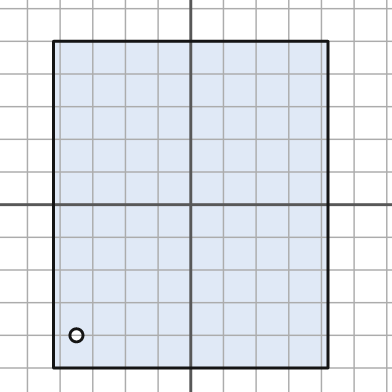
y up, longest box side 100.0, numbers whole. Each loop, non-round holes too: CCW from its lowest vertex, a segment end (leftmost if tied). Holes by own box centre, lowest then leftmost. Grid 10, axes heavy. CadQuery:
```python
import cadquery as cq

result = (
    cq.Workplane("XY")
    .moveTo(-42.0, -50.0)
    .lineTo(42.0, -50.0)
    .lineTo(42.0, 50.0)
    .lineTo(-42.0, 50.0)
    .close()
    .moveTo(-35.0, -40.0)
    .circle(2.0)
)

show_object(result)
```